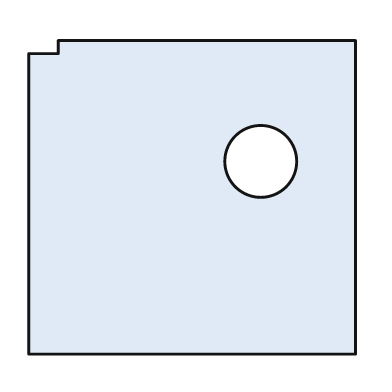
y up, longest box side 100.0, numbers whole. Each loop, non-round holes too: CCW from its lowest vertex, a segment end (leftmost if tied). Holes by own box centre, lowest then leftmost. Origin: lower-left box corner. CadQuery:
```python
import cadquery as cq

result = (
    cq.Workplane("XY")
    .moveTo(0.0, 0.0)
    .lineTo(100.0, 0.0)
    .lineTo(100.0, 96.0)
    .lineTo(9.0, 96.0)
    .lineTo(9.0, 92.0)
    .lineTo(0.0, 92.0)
    .close()
    .moveTo(71.0, 59.0)
    .circle(11.0)
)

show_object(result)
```